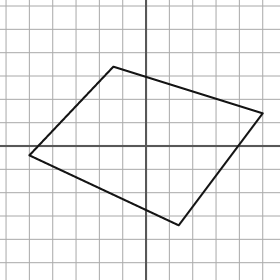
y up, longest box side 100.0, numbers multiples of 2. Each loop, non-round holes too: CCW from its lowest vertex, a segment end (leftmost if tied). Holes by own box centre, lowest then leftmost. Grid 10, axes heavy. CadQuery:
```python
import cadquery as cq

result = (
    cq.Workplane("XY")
    .moveTo(14.0, -34.0)
    .lineTo(50.0, 14.0)
    .lineTo(-14.0, 34.0)
    .lineTo(-50.0, -4.0)
    .close()
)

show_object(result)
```